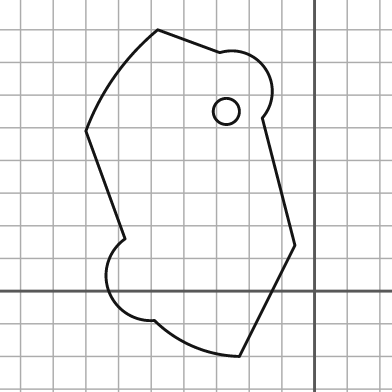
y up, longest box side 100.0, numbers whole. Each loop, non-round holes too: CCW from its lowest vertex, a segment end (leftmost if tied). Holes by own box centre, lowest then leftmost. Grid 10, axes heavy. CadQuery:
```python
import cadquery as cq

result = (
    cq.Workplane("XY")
    .moveTo(-23.0, -20.0)
    .lineTo(-6.0, 14.0)
    .lineTo(-16.0, 53.0)
    .threePointArc((-15.0, 68.0), (-29.0, 73.0))
    .lineTo(-48.0, 80.0)
    .threePointArc((-61.0, 66.0), (-70.0, 49.0))
    .lineTo(-58.0, 16.0)
    .threePointArc((-63.0, 0.0), (-49.0, -9.0))
    .threePointArc((-37.0, -17.0), (-23.0, -20.0))
    .close()
    .moveTo(-27.0, 55.0)
    .circle(4.0)
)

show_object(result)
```